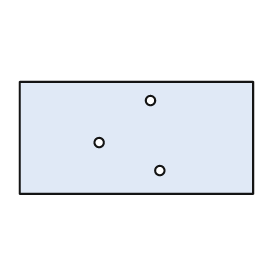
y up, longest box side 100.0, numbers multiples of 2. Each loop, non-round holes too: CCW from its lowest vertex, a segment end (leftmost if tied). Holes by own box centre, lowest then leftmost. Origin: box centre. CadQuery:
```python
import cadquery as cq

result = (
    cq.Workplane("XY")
    .moveTo(-50.0, -24.0)
    .lineTo(50.0, -24.0)
    .lineTo(50.0, 24.0)
    .lineTo(-50.0, 24.0)
    .close()
    .moveTo(10.0, -14.0)
    .circle(2.0)
    .moveTo(-16.0, -2.0)
    .circle(2.0)
    .moveTo(6.0, 16.0)
    .circle(2.0)
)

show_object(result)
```